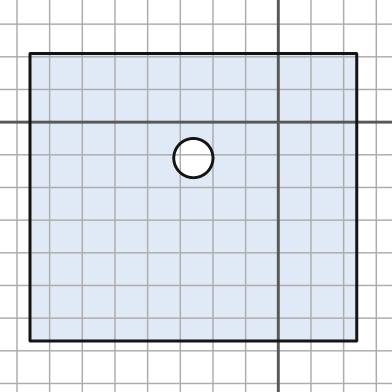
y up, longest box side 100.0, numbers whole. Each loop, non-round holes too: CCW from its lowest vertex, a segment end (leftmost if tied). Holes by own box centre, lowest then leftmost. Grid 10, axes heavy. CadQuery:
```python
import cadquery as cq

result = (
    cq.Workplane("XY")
    .moveTo(-76.0, -67.0)
    .lineTo(24.0, -67.0)
    .lineTo(24.0, 21.0)
    .lineTo(-76.0, 21.0)
    .close()
    .moveTo(-26.0, -11.0)
    .circle(6.0)
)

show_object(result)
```